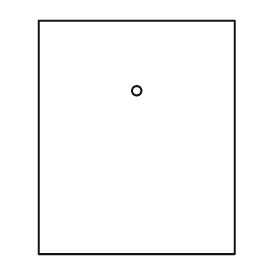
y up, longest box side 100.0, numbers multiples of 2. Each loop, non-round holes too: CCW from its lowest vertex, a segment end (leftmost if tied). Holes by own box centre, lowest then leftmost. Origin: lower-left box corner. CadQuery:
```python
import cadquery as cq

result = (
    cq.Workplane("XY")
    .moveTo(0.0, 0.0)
    .lineTo(84.0, 0.0)
    .lineTo(84.0, 100.0)
    .lineTo(0.0, 100.0)
    .close()
    .moveTo(42.0, 70.0)
    .circle(2.0)
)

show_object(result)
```